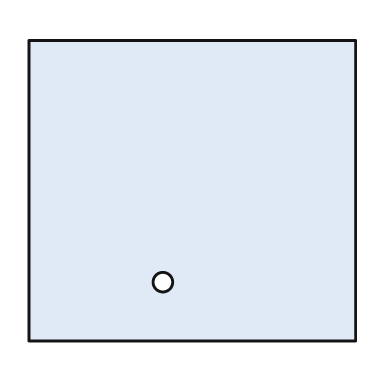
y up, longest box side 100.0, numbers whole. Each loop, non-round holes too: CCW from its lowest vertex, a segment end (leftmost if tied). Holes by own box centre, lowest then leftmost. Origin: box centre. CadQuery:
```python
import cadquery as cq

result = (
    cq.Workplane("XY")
    .moveTo(-50.0, -46.0)
    .lineTo(50.0, -46.0)
    .lineTo(50.0, 46.0)
    .lineTo(-50.0, 46.0)
    .close()
    .moveTo(-9.0, -28.0)
    .circle(3.0)
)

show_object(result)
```